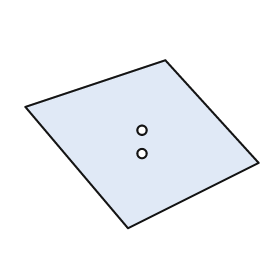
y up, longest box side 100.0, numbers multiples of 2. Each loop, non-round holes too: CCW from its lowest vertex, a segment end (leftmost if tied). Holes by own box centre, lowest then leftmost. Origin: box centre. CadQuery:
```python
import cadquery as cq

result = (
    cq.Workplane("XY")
    .moveTo(-6.0, -36.0)
    .lineTo(50.0, -8.0)
    .lineTo(10.0, 36.0)
    .lineTo(-50.0, 16.0)
    .close()
    .moveTo(0.0, -4.0)
    .circle(2.0)
    .moveTo(0.0, 6.0)
    .circle(2.0)
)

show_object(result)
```